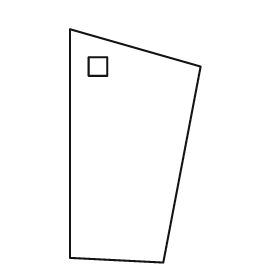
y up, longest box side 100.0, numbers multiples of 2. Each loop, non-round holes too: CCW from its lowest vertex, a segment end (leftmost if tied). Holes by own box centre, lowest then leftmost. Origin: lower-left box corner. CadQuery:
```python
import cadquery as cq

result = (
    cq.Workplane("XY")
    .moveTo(40.0, 0.0)
    .lineTo(56.0, 84.0)
    .lineTo(0.0, 100.0)
    .lineTo(0.0, 2.0)
    .close()
    .moveTo(8.0, 80.0)
    .lineTo(16.0, 80.0)
    .lineTo(16.0, 88.0)
    .lineTo(8.0, 88.0)
    .close()
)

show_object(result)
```